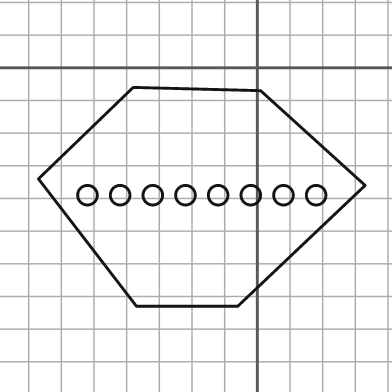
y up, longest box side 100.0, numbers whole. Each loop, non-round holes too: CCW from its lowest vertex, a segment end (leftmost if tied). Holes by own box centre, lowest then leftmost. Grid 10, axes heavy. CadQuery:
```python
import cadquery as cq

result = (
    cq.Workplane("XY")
    .moveTo(-37.0, -73.0)
    .lineTo(-6.0, -73.0)
    .lineTo(33.0, -36.0)
    .lineTo(1.0, -7.0)
    .lineTo(-38.0, -6.0)
    .lineTo(-67.0, -34.0)
    .close()
    .moveTo(-52.0, -39.0)
    .circle(3.0)
    .moveTo(-42.0, -39.0)
    .circle(3.0)
    .moveTo(-32.0, -39.0)
    .circle(3.0)
    .moveTo(-22.0, -39.0)
    .circle(3.0)
    .moveTo(-12.0, -39.0)
    .circle(3.0)
    .moveTo(-2.0, -39.0)
    .circle(3.0)
    .moveTo(8.0, -39.0)
    .circle(3.0)
    .moveTo(18.0, -39.0)
    .circle(3.0)
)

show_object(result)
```